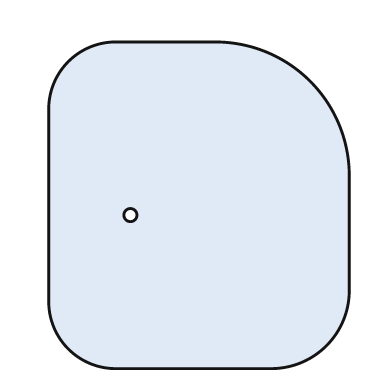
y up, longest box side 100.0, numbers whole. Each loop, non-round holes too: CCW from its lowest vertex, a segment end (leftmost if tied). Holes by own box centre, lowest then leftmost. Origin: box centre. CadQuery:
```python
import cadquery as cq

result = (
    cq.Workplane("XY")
    .moveTo(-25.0, -50.0)
    .lineTo(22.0, -50.0)
    .threePointArc((39.0, -43.0), (46.0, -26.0))
    .lineTo(46.0, 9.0)
    .threePointArc((34.0, 38.0), (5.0, 50.0))
    .lineTo(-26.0, 50.0)
    .threePointArc((-40.0, 44.0), (-46.0, 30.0))
    .lineTo(-46.0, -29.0)
    .threePointArc((-40.0, -44.0), (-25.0, -50.0))
    .close()
    .moveTo(-21.0, -3.0)
    .circle(2.0)
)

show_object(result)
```